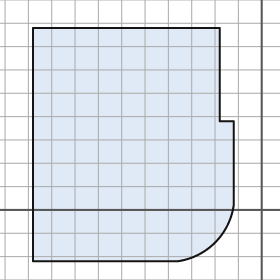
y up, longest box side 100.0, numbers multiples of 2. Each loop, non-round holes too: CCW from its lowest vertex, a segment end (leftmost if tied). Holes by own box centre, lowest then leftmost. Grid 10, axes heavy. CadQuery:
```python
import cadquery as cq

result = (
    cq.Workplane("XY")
    .moveTo(-98.0, -22.0)
    .lineTo(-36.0, -22.0)
    .threePointArc((-20.0, -14.0), (-12.0, 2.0))
    .lineTo(-12.0, 38.0)
    .lineTo(-18.0, 38.0)
    .lineTo(-18.0, 78.0)
    .lineTo(-98.0, 78.0)
    .close()
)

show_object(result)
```